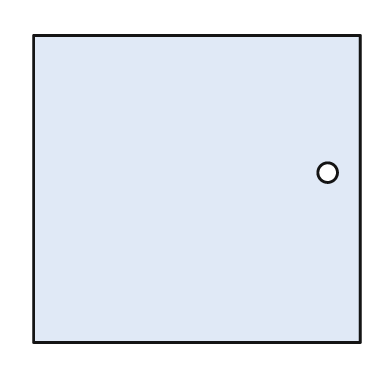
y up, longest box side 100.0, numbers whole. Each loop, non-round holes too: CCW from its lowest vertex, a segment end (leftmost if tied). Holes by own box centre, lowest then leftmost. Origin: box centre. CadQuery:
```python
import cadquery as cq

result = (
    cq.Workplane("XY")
    .moveTo(-50.0, -47.0)
    .lineTo(50.0, -47.0)
    .lineTo(50.0, 47.0)
    .lineTo(-50.0, 47.0)
    .close()
    .moveTo(40.0, 5.0)
    .circle(3.0)
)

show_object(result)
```